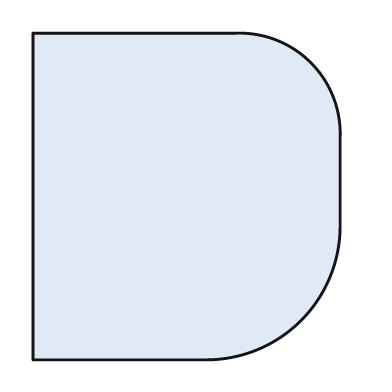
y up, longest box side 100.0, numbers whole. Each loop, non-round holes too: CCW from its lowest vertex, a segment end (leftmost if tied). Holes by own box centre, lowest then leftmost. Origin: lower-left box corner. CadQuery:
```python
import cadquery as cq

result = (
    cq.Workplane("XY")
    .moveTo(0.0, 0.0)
    .lineTo(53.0, 0.0)
    .threePointArc((82.0, 12.0), (94.0, 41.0))
    .lineTo(94.0, 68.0)
    .threePointArc((85.0, 91.0), (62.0, 100.0))
    .lineTo(0.0, 100.0)
    .close()
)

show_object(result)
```